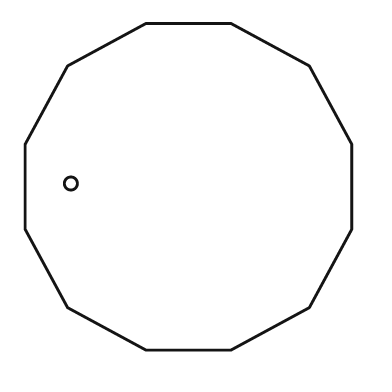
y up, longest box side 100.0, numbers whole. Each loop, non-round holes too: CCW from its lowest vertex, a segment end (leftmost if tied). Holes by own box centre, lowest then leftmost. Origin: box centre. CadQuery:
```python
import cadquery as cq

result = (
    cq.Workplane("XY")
    .moveTo(-13.0, -50.0)
    .lineTo(13.0, -50.0)
    .lineTo(37.0, -37.0)
    .lineTo(50.0, -13.0)
    .lineTo(50.0, 13.0)
    .lineTo(37.0, 37.0)
    .lineTo(13.0, 50.0)
    .lineTo(-13.0, 50.0)
    .lineTo(-37.0, 37.0)
    .lineTo(-50.0, 13.0)
    .lineTo(-50.0, -13.0)
    .lineTo(-37.0, -37.0)
    .close()
    .moveTo(-36.0, 1.0)
    .circle(2.0)
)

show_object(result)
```